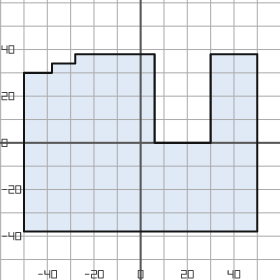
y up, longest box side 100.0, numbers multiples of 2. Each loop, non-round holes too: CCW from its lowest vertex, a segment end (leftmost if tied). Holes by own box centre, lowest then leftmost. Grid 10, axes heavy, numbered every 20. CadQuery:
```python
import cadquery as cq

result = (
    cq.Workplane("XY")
    .moveTo(-50.0, -38.0)
    .lineTo(50.0, -38.0)
    .lineTo(50.0, 38.0)
    .lineTo(30.0, 38.0)
    .lineTo(30.0, 0.0)
    .lineTo(6.0, 0.0)
    .lineTo(6.0, 38.0)
    .lineTo(-28.0, 38.0)
    .lineTo(-28.0, 34.0)
    .lineTo(-38.0, 34.0)
    .lineTo(-38.0, 30.0)
    .lineTo(-50.0, 30.0)
    .close()
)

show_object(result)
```